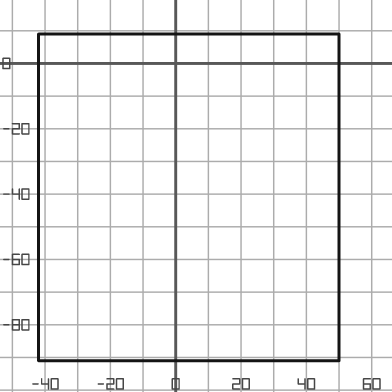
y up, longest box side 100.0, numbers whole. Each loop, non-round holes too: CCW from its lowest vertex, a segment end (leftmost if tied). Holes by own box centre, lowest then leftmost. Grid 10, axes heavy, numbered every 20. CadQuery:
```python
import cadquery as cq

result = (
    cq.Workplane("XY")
    .moveTo(-42.0, -91.0)
    .lineTo(50.0, -91.0)
    .lineTo(50.0, 9.0)
    .lineTo(-42.0, 9.0)
    .close()
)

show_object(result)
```